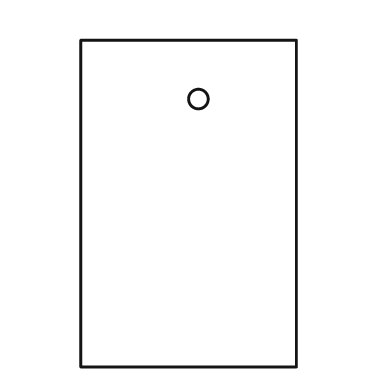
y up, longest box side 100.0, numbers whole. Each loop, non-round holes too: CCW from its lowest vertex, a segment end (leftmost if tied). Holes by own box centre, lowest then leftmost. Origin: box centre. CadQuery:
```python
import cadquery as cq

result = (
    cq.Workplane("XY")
    .moveTo(-33.0, -50.0)
    .lineTo(33.0, -50.0)
    .lineTo(33.0, 50.0)
    .lineTo(-33.0, 50.0)
    .close()
    .moveTo(3.0, 32.0)
    .circle(3.0)
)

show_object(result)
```